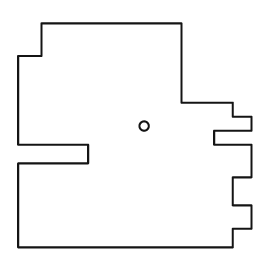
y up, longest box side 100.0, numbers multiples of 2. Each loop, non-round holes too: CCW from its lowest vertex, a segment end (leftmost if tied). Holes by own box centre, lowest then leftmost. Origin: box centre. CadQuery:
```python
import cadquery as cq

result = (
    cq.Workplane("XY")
    .moveTo(-50.0, -48.0)
    .lineTo(42.0, -48.0)
    .lineTo(42.0, -40.0)
    .lineTo(50.0, -40.0)
    .lineTo(50.0, -30.0)
    .lineTo(42.0, -30.0)
    .lineTo(42.0, -18.0)
    .lineTo(50.0, -18.0)
    .lineTo(50.0, -4.0)
    .lineTo(34.0, -4.0)
    .lineTo(34.0, 2.0)
    .lineTo(50.0, 2.0)
    .lineTo(50.0, 8.0)
    .lineTo(42.0, 8.0)
    .lineTo(42.0, 14.0)
    .lineTo(20.0, 14.0)
    .lineTo(20.0, 48.0)
    .lineTo(-40.0, 48.0)
    .lineTo(-40.0, 34.0)
    .lineTo(-50.0, 34.0)
    .lineTo(-50.0, -4.0)
    .lineTo(-20.0, -4.0)
    .lineTo(-20.0, -12.0)
    .lineTo(-50.0, -12.0)
    .close()
    .moveTo(4.0, 4.0)
    .circle(2.0)
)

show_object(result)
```